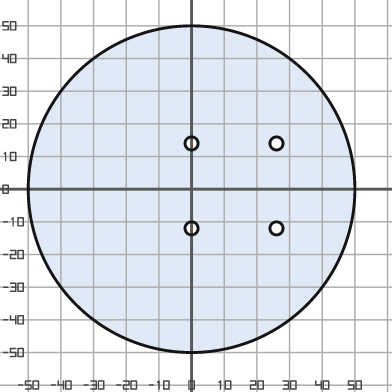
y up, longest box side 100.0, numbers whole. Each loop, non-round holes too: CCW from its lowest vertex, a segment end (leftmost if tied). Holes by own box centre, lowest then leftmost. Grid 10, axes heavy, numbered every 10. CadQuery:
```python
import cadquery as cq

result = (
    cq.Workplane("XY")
    .moveTo(0.0, 0.0)
    .circle(50.0)
    .moveTo(0.0, -12.0)
    .circle(2.0)
    .moveTo(26.0, -12.0)
    .circle(2.0)
    .moveTo(0.0, 14.0)
    .circle(2.0)
    .moveTo(26.0, 14.0)
    .circle(2.0)
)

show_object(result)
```